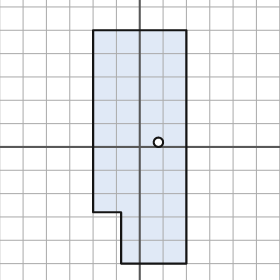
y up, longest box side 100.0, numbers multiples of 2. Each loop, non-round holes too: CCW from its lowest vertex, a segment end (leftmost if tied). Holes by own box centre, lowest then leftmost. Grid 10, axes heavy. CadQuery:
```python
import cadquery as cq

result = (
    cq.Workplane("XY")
    .moveTo(-8.0, -50.0)
    .lineTo(20.0, -50.0)
    .lineTo(20.0, 50.0)
    .lineTo(-20.0, 50.0)
    .lineTo(-20.0, -28.0)
    .lineTo(-8.0, -28.0)
    .close()
    .moveTo(8.0, 2.0)
    .circle(2.0)
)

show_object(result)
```